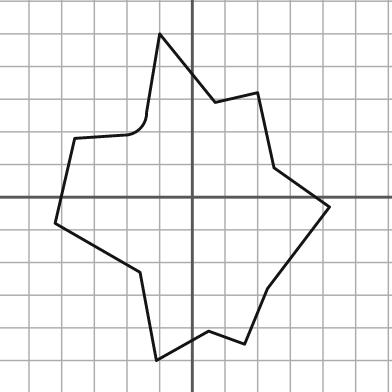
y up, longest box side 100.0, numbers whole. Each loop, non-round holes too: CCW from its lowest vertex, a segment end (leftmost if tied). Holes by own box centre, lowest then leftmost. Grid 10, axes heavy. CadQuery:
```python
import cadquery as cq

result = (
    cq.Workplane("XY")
    .moveTo(-11.0, -50.0)
    .lineTo(5.0, -41.0)
    .lineTo(16.0, -45.0)
    .lineTo(23.0, -28.0)
    .lineTo(42.0, -3.0)
    .lineTo(25.0, 9.0)
    .lineTo(20.0, 32.0)
    .lineTo(7.0, 29.0)
    .lineTo(-10.0, 50.0)
    .lineTo(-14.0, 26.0)
    .threePointArc((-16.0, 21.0), (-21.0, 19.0))
    .lineTo(-36.0, 18.0)
    .lineTo(-42.0, -8.0)
    .lineTo(-16.0, -23.0)
    .close()
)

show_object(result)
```